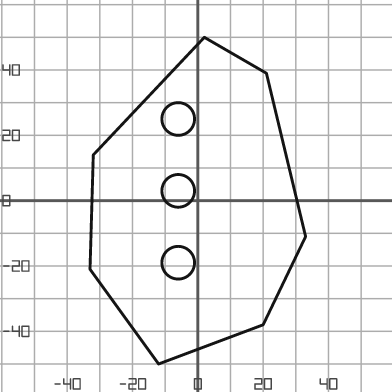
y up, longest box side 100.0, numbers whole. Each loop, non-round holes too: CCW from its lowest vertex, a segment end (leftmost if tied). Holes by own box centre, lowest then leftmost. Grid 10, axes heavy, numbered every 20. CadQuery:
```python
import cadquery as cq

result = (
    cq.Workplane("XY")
    .moveTo(-12.0, -50.0)
    .lineTo(20.0, -38.0)
    .lineTo(33.0, -11.0)
    .lineTo(21.0, 39.0)
    .lineTo(2.0, 50.0)
    .lineTo(-32.0, 14.0)
    .lineTo(-33.0, -21.0)
    .close()
    .moveTo(-6.0, -19.0)
    .circle(5.0)
    .moveTo(-6.0, 3.0)
    .circle(5.0)
    .moveTo(-6.0, 25.0)
    .circle(5.0)
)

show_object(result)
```